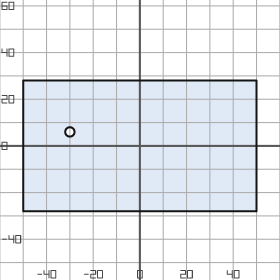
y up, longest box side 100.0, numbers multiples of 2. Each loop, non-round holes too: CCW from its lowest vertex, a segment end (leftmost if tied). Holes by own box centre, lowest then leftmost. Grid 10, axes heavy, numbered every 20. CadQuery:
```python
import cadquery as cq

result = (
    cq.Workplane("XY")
    .moveTo(-50.0, -28.0)
    .lineTo(50.0, -28.0)
    .lineTo(50.0, 28.0)
    .lineTo(-50.0, 28.0)
    .close()
    .moveTo(-30.0, 6.0)
    .circle(2.0)
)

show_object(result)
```